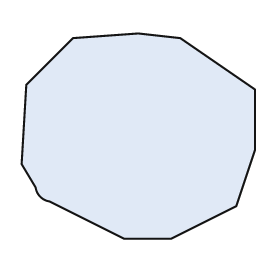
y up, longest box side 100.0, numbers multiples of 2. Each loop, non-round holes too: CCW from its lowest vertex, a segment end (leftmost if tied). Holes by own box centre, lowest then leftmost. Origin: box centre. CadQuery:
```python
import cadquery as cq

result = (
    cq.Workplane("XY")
    .moveTo(-6.0, -44.0)
    .lineTo(14.0, -44.0)
    .lineTo(42.0, -30.0)
    .lineTo(50.0, -6.0)
    .lineTo(50.0, 20.0)
    .lineTo(18.0, 42.0)
    .lineTo(0.0, 44.0)
    .lineTo(-28.0, 42.0)
    .lineTo(-48.0, 22.0)
    .lineTo(-50.0, -12.0)
    .lineTo(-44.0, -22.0)
    .threePointArc((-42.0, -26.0), (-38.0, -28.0))
    .close()
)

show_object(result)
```